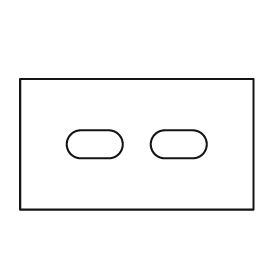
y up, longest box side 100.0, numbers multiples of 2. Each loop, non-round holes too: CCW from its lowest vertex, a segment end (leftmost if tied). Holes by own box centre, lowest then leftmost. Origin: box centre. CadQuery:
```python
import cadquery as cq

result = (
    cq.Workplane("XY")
    .moveTo(-50.0, -28.0)
    .lineTo(50.0, -28.0)
    .lineTo(50.0, 28.0)
    .lineTo(-50.0, 28.0)
    .close()
    .moveTo(-24.0, -6.0)
    .lineTo(-12.0, -6.0)
    .threePointArc((-6.0, 0.0), (-12.0, 6.0))
    .lineTo(-24.0, 6.0)
    .threePointArc((-30.0, 0.0), (-24.0, -6.0))
    .close()
    .moveTo(12.0, -6.0)
    .lineTo(24.0, -6.0)
    .threePointArc((30.0, 0.0), (24.0, 6.0))
    .lineTo(12.0, 6.0)
    .threePointArc((6.0, 0.0), (12.0, -6.0))
    .close()
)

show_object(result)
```